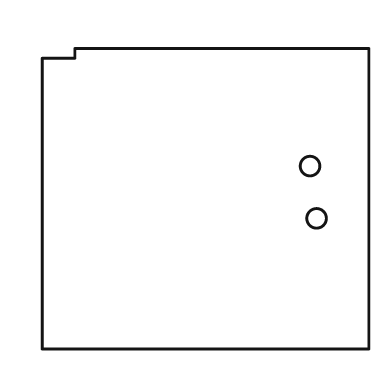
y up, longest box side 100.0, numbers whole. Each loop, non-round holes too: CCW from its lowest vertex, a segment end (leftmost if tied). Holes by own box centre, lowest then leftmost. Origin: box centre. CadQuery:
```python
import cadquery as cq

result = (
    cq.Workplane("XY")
    .moveTo(-50.0, -46.0)
    .lineTo(50.0, -46.0)
    .lineTo(50.0, 46.0)
    .lineTo(-40.0, 46.0)
    .lineTo(-40.0, 43.0)
    .lineTo(-50.0, 43.0)
    .close()
    .moveTo(34.0, -6.0)
    .circle(3.0)
    .moveTo(32.0, 10.0)
    .circle(3.0)
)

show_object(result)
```